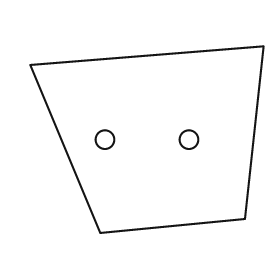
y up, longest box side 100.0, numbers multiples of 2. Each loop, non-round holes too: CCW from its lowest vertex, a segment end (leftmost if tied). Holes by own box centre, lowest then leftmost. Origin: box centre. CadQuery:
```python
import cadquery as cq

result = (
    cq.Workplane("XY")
    .moveTo(-20.0, -40.0)
    .lineTo(42.0, -34.0)
    .lineTo(50.0, 40.0)
    .lineTo(-50.0, 32.0)
    .close()
    .moveTo(-18.0, 0.0)
    .circle(4.0)
    .moveTo(18.0, 0.0)
    .circle(4.0)
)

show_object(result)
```